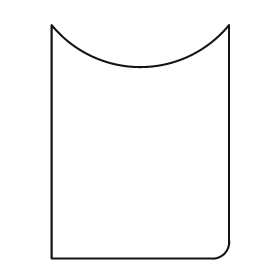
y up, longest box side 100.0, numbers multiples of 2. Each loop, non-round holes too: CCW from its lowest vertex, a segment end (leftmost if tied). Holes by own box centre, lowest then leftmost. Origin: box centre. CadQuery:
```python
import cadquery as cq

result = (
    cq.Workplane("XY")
    .moveTo(-38.0, -50.0)
    .lineTo(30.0, -50.0)
    .threePointArc((36.0, -48.0), (38.0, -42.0))
    .lineTo(38.0, 50.0)
    .threePointArc((0.0, 32.0), (-38.0, 50.0))
    .close()
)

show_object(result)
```